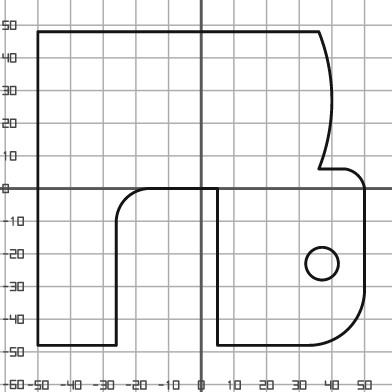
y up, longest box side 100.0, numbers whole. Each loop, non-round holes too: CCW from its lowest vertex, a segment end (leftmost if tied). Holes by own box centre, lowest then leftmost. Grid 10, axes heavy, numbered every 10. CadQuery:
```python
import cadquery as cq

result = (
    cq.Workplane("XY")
    .moveTo(-50.0, -48.0)
    .lineTo(-26.0, -48.0)
    .lineTo(-26.0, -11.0)
    .threePointArc((-23.0, -3.0), (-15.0, 0.0))
    .lineTo(5.0, 0.0)
    .lineTo(5.0, -48.0)
    .lineTo(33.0, -48.0)
    .threePointArc((45.0, -43.0), (50.0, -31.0))
    .lineTo(50.0, 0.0)
    .threePointArc((48.0, 4.0), (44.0, 6.0))
    .lineTo(36.0, 6.0)
    .threePointArc((40.0, 27.0), (36.0, 48.0))
    .lineTo(-50.0, 48.0)
    .close()
    .moveTo(37.0, -23.0)
    .circle(5.0)
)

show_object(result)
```